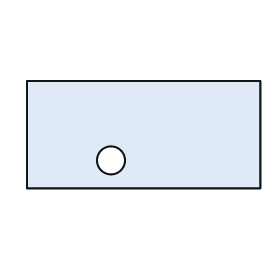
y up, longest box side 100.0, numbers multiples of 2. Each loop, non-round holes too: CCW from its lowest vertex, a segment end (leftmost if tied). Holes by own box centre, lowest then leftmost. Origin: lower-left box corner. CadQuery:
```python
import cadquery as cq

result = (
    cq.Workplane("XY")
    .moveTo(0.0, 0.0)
    .lineTo(100.0, 0.0)
    .lineTo(100.0, 46.0)
    .lineTo(0.0, 46.0)
    .close()
    .moveTo(36.0, 12.0)
    .circle(6.0)
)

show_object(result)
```